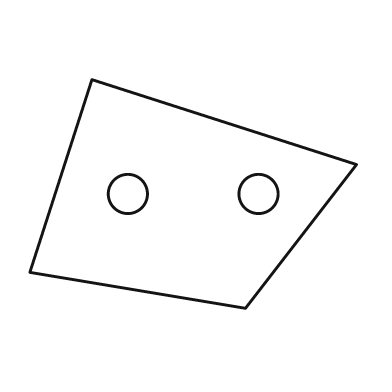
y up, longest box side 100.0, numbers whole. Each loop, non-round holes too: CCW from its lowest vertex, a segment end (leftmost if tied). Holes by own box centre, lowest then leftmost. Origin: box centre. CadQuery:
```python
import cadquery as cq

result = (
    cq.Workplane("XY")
    .moveTo(16.0, -35.0)
    .lineTo(50.0, 9.0)
    .lineTo(-31.0, 35.0)
    .lineTo(-50.0, -24.0)
    .close()
    .moveTo(-20.0, 0.0)
    .circle(6.0)
    .moveTo(20.0, 0.0)
    .circle(6.0)
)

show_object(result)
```